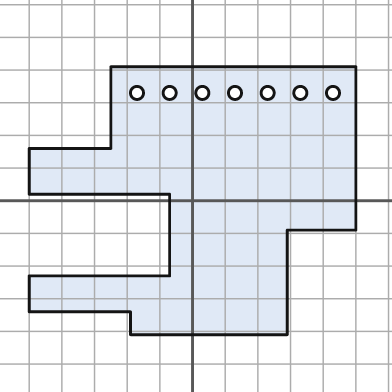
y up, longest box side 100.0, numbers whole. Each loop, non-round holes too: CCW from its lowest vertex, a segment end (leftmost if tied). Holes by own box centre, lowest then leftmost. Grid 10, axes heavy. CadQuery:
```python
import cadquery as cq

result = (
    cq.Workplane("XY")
    .moveTo(-19.0, -41.0)
    .lineTo(29.0, -41.0)
    .lineTo(29.0, -9.0)
    .lineTo(50.0, -9.0)
    .lineTo(50.0, 41.0)
    .lineTo(-25.0, 41.0)
    .lineTo(-25.0, 16.0)
    .lineTo(-50.0, 16.0)
    .lineTo(-50.0, 2.0)
    .lineTo(-7.0, 2.0)
    .lineTo(-7.0, -23.0)
    .lineTo(-50.0, -23.0)
    .lineTo(-50.0, -34.0)
    .lineTo(-19.0, -34.0)
    .close()
    .moveTo(-17.0, 33.0)
    .circle(2.0)
    .moveTo(-7.0, 33.0)
    .circle(2.0)
    .moveTo(3.0, 33.0)
    .circle(2.0)
    .moveTo(13.0, 33.0)
    .circle(2.0)
    .moveTo(23.0, 33.0)
    .circle(2.0)
    .moveTo(33.0, 33.0)
    .circle(2.0)
    .moveTo(43.0, 33.0)
    .circle(2.0)
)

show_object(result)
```